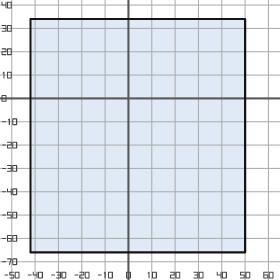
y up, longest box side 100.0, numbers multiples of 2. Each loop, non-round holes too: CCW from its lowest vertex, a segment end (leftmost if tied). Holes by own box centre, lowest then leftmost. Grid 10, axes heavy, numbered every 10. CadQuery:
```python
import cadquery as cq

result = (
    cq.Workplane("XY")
    .moveTo(-42.0, -66.0)
    .lineTo(50.0, -66.0)
    .lineTo(50.0, 34.0)
    .lineTo(-42.0, 34.0)
    .close()
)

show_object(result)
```